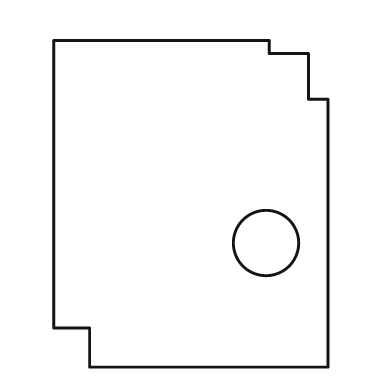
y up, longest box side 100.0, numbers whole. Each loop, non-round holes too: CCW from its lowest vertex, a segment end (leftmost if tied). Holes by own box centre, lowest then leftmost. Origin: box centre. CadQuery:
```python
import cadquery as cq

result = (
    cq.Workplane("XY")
    .moveTo(-31.0, -50.0)
    .lineTo(42.0, -50.0)
    .lineTo(42.0, 32.0)
    .lineTo(36.0, 32.0)
    .lineTo(36.0, 46.0)
    .lineTo(24.0, 46.0)
    .lineTo(24.0, 50.0)
    .lineTo(-42.0, 50.0)
    .lineTo(-42.0, -38.0)
    .lineTo(-31.0, -38.0)
    .close()
    .moveTo(23.0, -12.0)
    .circle(10.0)
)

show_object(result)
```